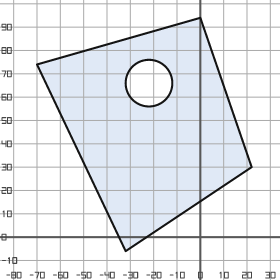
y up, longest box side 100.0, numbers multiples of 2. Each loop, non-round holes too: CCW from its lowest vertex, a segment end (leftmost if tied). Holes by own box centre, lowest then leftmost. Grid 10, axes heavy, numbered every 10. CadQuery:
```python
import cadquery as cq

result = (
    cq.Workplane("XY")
    .moveTo(-32.0, -6.0)
    .lineTo(22.0, 30.0)
    .lineTo(0.0, 94.0)
    .lineTo(-70.0, 74.0)
    .close()
    .moveTo(-22.0, 66.0)
    .circle(10.0)
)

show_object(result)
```